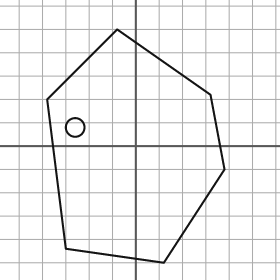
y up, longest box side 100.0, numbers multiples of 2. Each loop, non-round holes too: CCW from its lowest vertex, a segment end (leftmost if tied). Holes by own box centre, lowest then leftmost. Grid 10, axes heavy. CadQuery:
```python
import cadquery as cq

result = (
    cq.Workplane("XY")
    .moveTo(12.0, -50.0)
    .lineTo(38.0, -10.0)
    .lineTo(32.0, 22.0)
    .lineTo(-8.0, 50.0)
    .lineTo(-38.0, 20.0)
    .lineTo(-30.0, -44.0)
    .close()
    .moveTo(-26.0, 8.0)
    .circle(4.0)
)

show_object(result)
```